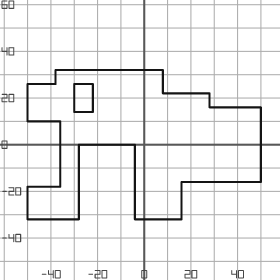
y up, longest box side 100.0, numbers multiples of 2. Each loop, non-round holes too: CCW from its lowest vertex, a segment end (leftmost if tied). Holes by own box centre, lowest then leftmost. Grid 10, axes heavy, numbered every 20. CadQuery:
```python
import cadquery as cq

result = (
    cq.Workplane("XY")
    .moveTo(-50.0, -32.0)
    .lineTo(-28.0, -32.0)
    .lineTo(-28.0, 0.0)
    .lineTo(-4.0, 0.0)
    .lineTo(-4.0, -32.0)
    .lineTo(16.0, -32.0)
    .lineTo(16.0, -16.0)
    .lineTo(50.0, -16.0)
    .lineTo(50.0, 16.0)
    .lineTo(28.0, 16.0)
    .lineTo(28.0, 22.0)
    .lineTo(8.0, 22.0)
    .lineTo(8.0, 32.0)
    .lineTo(-38.0, 32.0)
    .lineTo(-38.0, 26.0)
    .lineTo(-50.0, 26.0)
    .lineTo(-50.0, 10.0)
    .lineTo(-36.0, 10.0)
    .lineTo(-36.0, -18.0)
    .lineTo(-50.0, -18.0)
    .close()
    .moveTo(-30.0, 14.0)
    .lineTo(-22.0, 14.0)
    .lineTo(-22.0, 26.0)
    .lineTo(-30.0, 26.0)
    .close()
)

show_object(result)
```